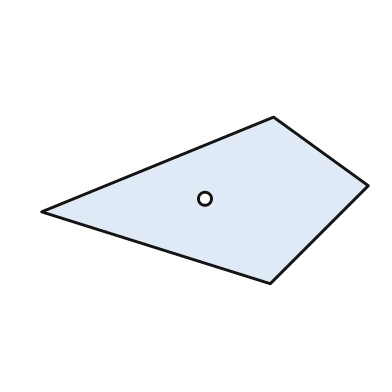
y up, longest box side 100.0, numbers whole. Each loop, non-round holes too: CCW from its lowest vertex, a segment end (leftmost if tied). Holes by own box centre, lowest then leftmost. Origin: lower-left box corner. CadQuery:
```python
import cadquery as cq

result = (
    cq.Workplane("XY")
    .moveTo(70.0, 0.0)
    .lineTo(100.0, 30.0)
    .lineTo(71.0, 51.0)
    .lineTo(0.0, 22.0)
    .close()
    .moveTo(50.0, 26.0)
    .circle(2.0)
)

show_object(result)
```